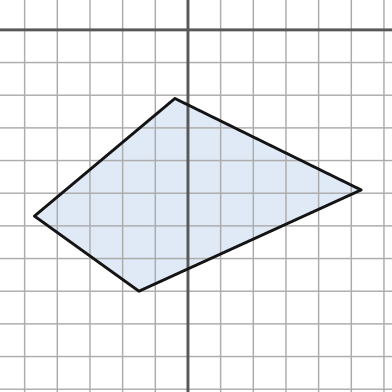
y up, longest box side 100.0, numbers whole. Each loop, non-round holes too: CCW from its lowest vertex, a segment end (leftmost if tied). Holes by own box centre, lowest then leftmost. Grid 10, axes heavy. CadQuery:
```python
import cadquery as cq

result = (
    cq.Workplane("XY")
    .moveTo(-15.0, -80.0)
    .lineTo(53.0, -49.0)
    .lineTo(-4.0, -21.0)
    .lineTo(-47.0, -57.0)
    .close()
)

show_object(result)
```